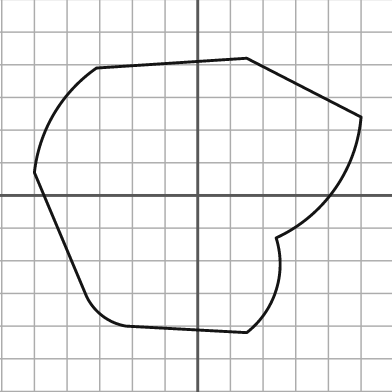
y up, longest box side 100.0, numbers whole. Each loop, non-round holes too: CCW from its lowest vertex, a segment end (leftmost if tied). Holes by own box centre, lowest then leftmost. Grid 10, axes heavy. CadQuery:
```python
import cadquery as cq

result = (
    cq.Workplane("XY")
    .moveTo(15.0, -42.0)
    .threePointArc((24.0, -29.0), (24.0, -13.0))
    .threePointArc((42.0, 2.0), (50.0, 24.0))
    .lineTo(15.0, 42.0)
    .lineTo(-31.0, 39.0)
    .threePointArc((-44.0, 25.0), (-50.0, 7.0))
    .lineTo(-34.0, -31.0)
    .threePointArc((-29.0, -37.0), (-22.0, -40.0))
    .close()
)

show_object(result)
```